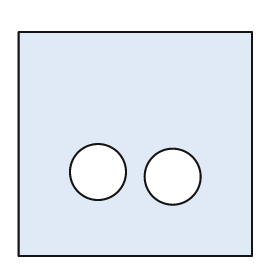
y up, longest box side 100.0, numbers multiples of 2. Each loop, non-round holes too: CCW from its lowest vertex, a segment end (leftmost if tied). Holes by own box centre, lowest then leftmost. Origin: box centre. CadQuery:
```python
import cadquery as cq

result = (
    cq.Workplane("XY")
    .moveTo(-50.0, -48.0)
    .lineTo(50.0, -48.0)
    .lineTo(50.0, 48.0)
    .lineTo(-50.0, 48.0)
    .close()
    .moveTo(16.0, -14.0)
    .circle(12.0)
    .moveTo(-16.0, -12.0)
    .circle(12.0)
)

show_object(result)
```